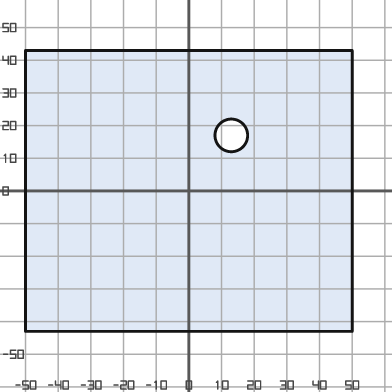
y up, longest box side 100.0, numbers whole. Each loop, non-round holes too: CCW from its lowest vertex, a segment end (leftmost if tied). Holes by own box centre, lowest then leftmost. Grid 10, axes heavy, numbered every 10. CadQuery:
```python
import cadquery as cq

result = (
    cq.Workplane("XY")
    .moveTo(-50.0, -43.0)
    .lineTo(50.0, -43.0)
    .lineTo(50.0, 43.0)
    .lineTo(-50.0, 43.0)
    .close()
    .moveTo(13.0, 17.0)
    .circle(5.0)
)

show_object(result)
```